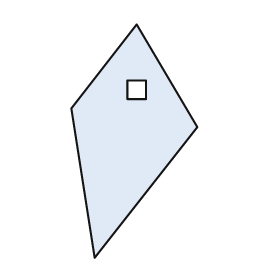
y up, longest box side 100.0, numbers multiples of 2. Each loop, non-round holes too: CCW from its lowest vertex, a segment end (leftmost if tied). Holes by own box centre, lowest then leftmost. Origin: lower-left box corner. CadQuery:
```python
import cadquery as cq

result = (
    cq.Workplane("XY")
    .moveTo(10.0, 0.0)
    .lineTo(54.0, 56.0)
    .lineTo(28.0, 100.0)
    .lineTo(0.0, 64.0)
    .close()
    .moveTo(24.0, 68.0)
    .lineTo(32.0, 68.0)
    .lineTo(32.0, 76.0)
    .lineTo(24.0, 76.0)
    .close()
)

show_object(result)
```